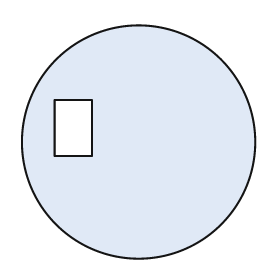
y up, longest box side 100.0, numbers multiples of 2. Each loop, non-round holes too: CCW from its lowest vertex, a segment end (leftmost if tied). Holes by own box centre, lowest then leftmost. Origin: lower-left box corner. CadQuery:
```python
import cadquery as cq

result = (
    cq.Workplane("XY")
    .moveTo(50.0, 50.0)
    .circle(50.0)
    .moveTo(14.0, 44.0)
    .lineTo(30.0, 44.0)
    .lineTo(30.0, 68.0)
    .lineTo(14.0, 68.0)
    .close()
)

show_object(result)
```